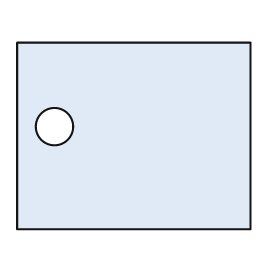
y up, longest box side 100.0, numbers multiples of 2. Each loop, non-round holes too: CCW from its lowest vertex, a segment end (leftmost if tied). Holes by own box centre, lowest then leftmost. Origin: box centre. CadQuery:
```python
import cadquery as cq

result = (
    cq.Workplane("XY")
    .moveTo(-50.0, -40.0)
    .lineTo(50.0, -40.0)
    .lineTo(50.0, 40.0)
    .lineTo(-50.0, 40.0)
    .close()
    .moveTo(-34.0, 4.0)
    .circle(8.0)
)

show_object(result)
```